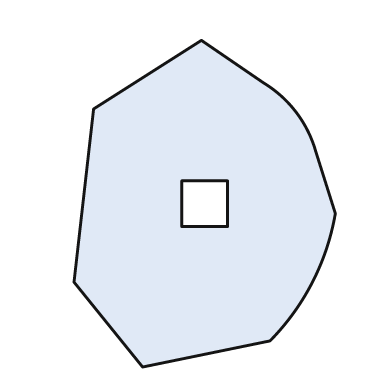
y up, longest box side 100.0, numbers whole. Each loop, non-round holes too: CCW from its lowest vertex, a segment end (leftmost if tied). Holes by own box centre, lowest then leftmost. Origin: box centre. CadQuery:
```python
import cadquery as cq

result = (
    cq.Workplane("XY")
    .moveTo(-19.0, -50.0)
    .lineTo(20.0, -42.0)
    .threePointArc((33.0, -24.0), (40.0, -3.0))
    .lineTo(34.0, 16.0)
    .threePointArc((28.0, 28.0), (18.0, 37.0))
    .lineTo(-1.0, 50.0)
    .lineTo(-34.0, 29.0)
    .lineTo(-40.0, -24.0)
    .close()
    .moveTo(-7.0, -7.0)
    .lineTo(7.0, -7.0)
    .lineTo(7.0, 7.0)
    .lineTo(-7.0, 7.0)
    .close()
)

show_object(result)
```